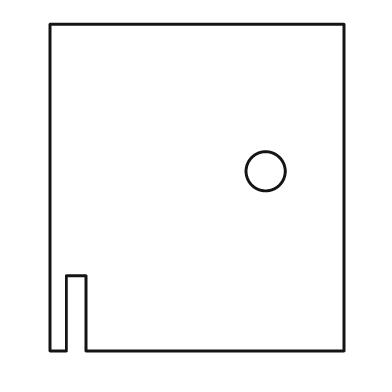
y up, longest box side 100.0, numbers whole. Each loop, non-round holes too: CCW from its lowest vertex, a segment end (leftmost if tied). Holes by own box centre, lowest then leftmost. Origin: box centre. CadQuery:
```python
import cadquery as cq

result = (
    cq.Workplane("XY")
    .moveTo(-45.0, -50.0)
    .lineTo(-40.0, -50.0)
    .lineTo(-40.0, -27.0)
    .lineTo(-34.0, -27.0)
    .lineTo(-34.0, -50.0)
    .lineTo(45.0, -50.0)
    .lineTo(45.0, 50.0)
    .lineTo(-45.0, 50.0)
    .close()
    .moveTo(21.0, 5.0)
    .circle(6.0)
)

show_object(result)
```